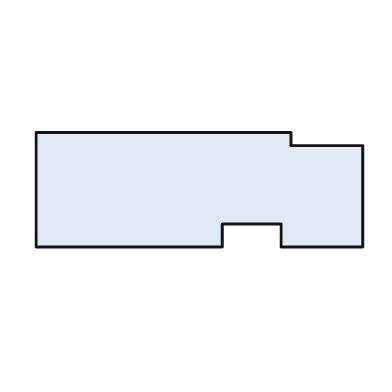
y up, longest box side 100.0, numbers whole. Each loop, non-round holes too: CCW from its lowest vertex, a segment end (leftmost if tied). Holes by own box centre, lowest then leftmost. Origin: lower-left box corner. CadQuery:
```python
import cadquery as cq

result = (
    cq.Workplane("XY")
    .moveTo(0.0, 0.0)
    .lineTo(57.0, 0.0)
    .lineTo(57.0, 7.0)
    .lineTo(75.0, 7.0)
    .lineTo(75.0, 0.0)
    .lineTo(100.0, 0.0)
    .lineTo(100.0, 31.0)
    .lineTo(78.0, 31.0)
    .lineTo(78.0, 35.0)
    .lineTo(0.0, 35.0)
    .close()
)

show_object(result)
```